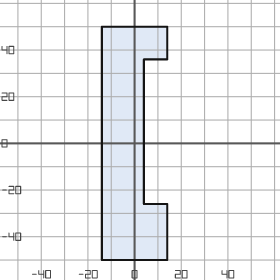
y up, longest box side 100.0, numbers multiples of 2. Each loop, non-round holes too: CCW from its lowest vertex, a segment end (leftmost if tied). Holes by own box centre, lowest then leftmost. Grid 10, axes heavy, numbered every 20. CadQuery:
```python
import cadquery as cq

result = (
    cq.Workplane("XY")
    .moveTo(-14.0, -50.0)
    .lineTo(14.0, -50.0)
    .lineTo(14.0, -26.0)
    .lineTo(4.0, -26.0)
    .lineTo(4.0, 36.0)
    .lineTo(14.0, 36.0)
    .lineTo(14.0, 50.0)
    .lineTo(-14.0, 50.0)
    .close()
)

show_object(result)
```